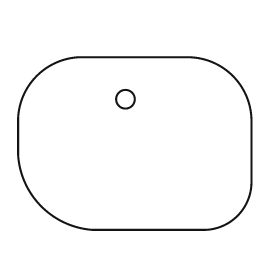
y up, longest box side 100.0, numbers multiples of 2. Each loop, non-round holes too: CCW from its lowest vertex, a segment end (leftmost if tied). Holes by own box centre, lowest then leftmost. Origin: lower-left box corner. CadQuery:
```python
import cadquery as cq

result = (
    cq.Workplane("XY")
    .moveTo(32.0, 0.0)
    .lineTo(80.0, 0.0)
    .threePointArc((94.0, 6.0), (100.0, 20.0))
    .lineTo(100.0, 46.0)
    .threePointArc((92.0, 66.0), (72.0, 74.0))
    .lineTo(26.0, 74.0)
    .threePointArc((8.0, 66.0), (0.0, 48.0))
    .lineTo(0.0, 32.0)
    .threePointArc((10.0, 10.0), (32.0, 0.0))
    .close()
    .moveTo(46.0, 56.0)
    .circle(4.0)
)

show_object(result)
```